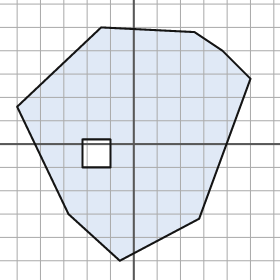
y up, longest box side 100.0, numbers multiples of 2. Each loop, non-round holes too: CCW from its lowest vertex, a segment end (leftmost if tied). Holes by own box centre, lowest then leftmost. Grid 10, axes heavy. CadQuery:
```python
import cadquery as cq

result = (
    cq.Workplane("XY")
    .moveTo(-6.0, -50.0)
    .lineTo(28.0, -32.0)
    .lineTo(50.0, 28.0)
    .lineTo(38.0, 40.0)
    .lineTo(26.0, 48.0)
    .lineTo(-14.0, 50.0)
    .lineTo(-50.0, 16.0)
    .lineTo(-28.0, -30.0)
    .close()
    .moveTo(-22.0, -10.0)
    .lineTo(-10.0, -10.0)
    .lineTo(-10.0, 2.0)
    .lineTo(-22.0, 2.0)
    .close()
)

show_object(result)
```